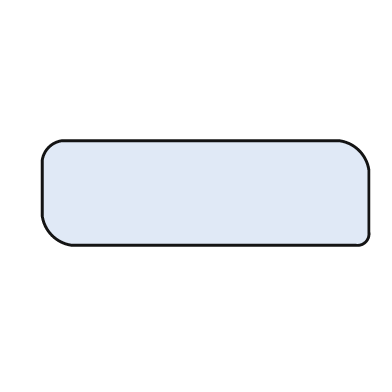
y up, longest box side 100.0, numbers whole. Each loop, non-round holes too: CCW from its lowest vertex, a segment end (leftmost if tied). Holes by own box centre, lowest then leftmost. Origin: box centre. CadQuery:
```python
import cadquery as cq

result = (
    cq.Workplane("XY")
    .moveTo(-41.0, -16.0)
    .lineTo(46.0, -16.0)
    .threePointArc((49.0, -15.0), (50.0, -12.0))
    .lineTo(50.0, 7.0)
    .threePointArc((47.0, 13.0), (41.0, 16.0))
    .lineTo(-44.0, 16.0)
    .threePointArc((-48.0, 14.0), (-50.0, 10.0))
    .lineTo(-50.0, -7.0)
    .threePointArc((-47.0, -13.0), (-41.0, -16.0))
    .close()
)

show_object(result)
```